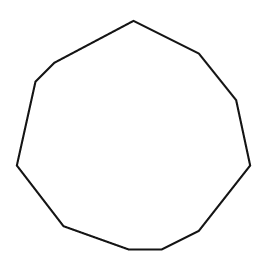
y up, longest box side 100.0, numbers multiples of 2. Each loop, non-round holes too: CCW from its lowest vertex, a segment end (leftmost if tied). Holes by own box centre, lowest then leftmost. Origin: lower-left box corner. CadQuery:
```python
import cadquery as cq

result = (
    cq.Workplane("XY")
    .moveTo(48.0, 0.0)
    .lineTo(62.0, 0.0)
    .lineTo(78.0, 8.0)
    .lineTo(100.0, 36.0)
    .lineTo(94.0, 64.0)
    .lineTo(78.0, 84.0)
    .lineTo(50.0, 98.0)
    .lineTo(16.0, 80.0)
    .lineTo(8.0, 72.0)
    .lineTo(0.0, 36.0)
    .lineTo(20.0, 10.0)
    .close()
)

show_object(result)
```